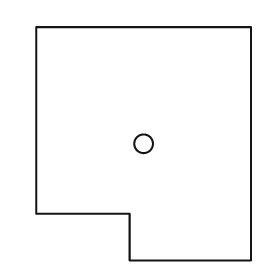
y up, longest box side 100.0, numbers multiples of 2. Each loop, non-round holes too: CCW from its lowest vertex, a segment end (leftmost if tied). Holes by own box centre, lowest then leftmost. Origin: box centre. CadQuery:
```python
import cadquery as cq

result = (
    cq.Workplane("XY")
    .moveTo(-6.0, -50.0)
    .lineTo(46.0, -50.0)
    .lineTo(46.0, 50.0)
    .lineTo(-46.0, 50.0)
    .lineTo(-46.0, -30.0)
    .lineTo(-6.0, -30.0)
    .close()
    .moveTo(0.0, 0.0)
    .circle(4.0)
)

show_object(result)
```